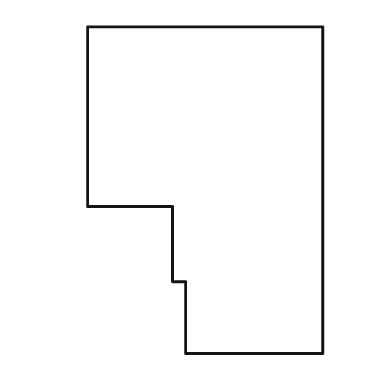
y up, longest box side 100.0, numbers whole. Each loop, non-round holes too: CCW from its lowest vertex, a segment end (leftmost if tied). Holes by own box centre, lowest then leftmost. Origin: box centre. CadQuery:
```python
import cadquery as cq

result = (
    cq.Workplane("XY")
    .moveTo(-6.0, -50.0)
    .lineTo(36.0, -50.0)
    .lineTo(36.0, 50.0)
    .lineTo(-36.0, 50.0)
    .lineTo(-36.0, -5.0)
    .lineTo(-10.0, -5.0)
    .lineTo(-10.0, -28.0)
    .lineTo(-6.0, -28.0)
    .close()
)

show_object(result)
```